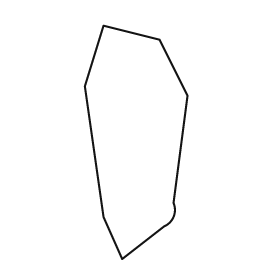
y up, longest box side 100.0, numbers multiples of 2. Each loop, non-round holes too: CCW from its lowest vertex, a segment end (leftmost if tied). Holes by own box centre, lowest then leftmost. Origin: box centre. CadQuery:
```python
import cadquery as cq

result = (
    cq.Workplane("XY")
    .moveTo(-6.0, -50.0)
    .lineTo(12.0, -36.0)
    .threePointArc((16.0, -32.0), (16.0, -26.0))
    .lineTo(22.0, 20.0)
    .lineTo(10.0, 44.0)
    .lineTo(-14.0, 50.0)
    .lineTo(-22.0, 24.0)
    .lineTo(-14.0, -32.0)
    .close()
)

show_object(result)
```